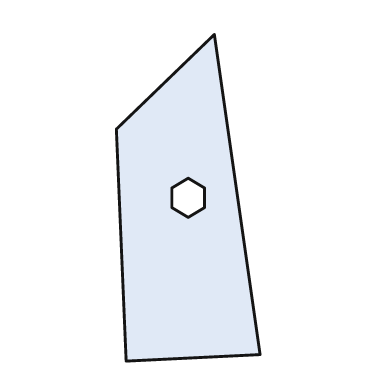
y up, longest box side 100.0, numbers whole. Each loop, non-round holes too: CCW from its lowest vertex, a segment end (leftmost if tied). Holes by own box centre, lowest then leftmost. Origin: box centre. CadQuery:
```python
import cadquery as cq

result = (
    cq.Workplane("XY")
    .moveTo(-19.0, -50.0)
    .lineTo(22.0, -48.0)
    .lineTo(8.0, 50.0)
    .lineTo(-22.0, 21.0)
    .close()
    .moveTo(0.0, -6.0)
    .lineTo(5.0, -3.0)
    .lineTo(5.0, 3.0)
    .lineTo(0.0, 6.0)
    .lineTo(-5.0, 3.0)
    .lineTo(-5.0, -3.0)
    .close()
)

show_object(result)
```